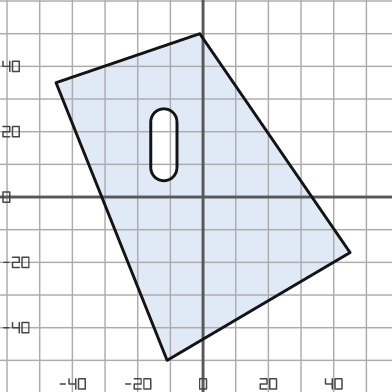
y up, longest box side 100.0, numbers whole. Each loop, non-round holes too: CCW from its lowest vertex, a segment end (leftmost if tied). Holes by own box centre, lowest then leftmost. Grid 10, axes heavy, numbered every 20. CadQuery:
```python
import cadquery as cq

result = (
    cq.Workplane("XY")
    .moveTo(-11.0, -50.0)
    .lineTo(45.0, -17.0)
    .lineTo(-1.0, 50.0)
    .lineTo(-45.0, 35.0)
    .close()
    .moveTo(-16.0, 9.0)
    .threePointArc((-12.0, 5.0), (-8.0, 9.0))
    .lineTo(-8.0, 23.0)
    .threePointArc((-12.0, 27.0), (-16.0, 23.0))
    .close()
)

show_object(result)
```